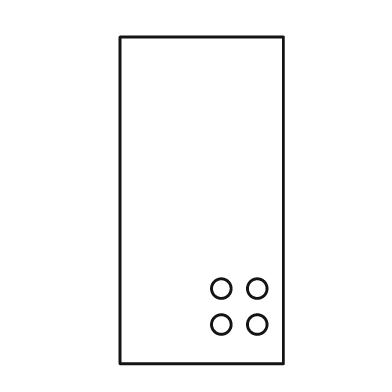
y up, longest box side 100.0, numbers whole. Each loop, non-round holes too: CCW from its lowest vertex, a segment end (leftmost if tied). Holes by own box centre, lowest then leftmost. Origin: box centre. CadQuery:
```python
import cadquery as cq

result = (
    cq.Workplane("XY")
    .moveTo(-25.0, -50.0)
    .lineTo(25.0, -50.0)
    .lineTo(25.0, 50.0)
    .lineTo(-25.0, 50.0)
    .close()
    .moveTo(6.0, -38.0)
    .circle(3.0)
    .moveTo(17.0, -38.0)
    .circle(3.0)
    .moveTo(6.0, -27.0)
    .circle(3.0)
    .moveTo(17.0, -27.0)
    .circle(3.0)
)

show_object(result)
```